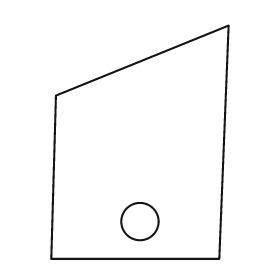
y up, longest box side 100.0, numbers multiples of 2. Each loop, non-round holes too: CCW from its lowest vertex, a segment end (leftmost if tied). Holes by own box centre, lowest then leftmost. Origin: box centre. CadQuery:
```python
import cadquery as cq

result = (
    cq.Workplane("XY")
    .moveTo(-38.0, -50.0)
    .lineTo(34.0, -50.0)
    .lineTo(38.0, 50.0)
    .lineTo(-36.0, 20.0)
    .close()
    .moveTo(0.0, -34.0)
    .circle(8.0)
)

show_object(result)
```